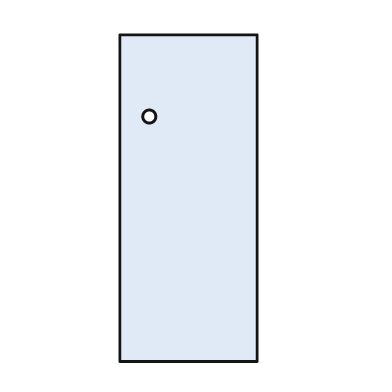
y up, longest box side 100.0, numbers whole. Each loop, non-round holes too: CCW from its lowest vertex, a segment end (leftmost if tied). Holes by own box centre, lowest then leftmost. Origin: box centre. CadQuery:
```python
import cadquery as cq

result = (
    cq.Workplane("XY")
    .moveTo(-21.0, -50.0)
    .lineTo(21.0, -50.0)
    .lineTo(21.0, 50.0)
    .lineTo(-21.0, 50.0)
    .close()
    .moveTo(-12.0, 25.0)
    .circle(2.0)
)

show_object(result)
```